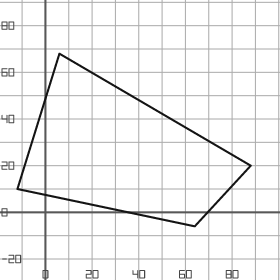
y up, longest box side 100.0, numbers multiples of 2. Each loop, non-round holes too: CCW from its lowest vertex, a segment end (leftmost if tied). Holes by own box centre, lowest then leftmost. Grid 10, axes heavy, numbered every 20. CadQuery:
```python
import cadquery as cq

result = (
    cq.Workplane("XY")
    .moveTo(64.0, -6.0)
    .lineTo(88.0, 20.0)
    .lineTo(6.0, 68.0)
    .lineTo(-12.0, 10.0)
    .close()
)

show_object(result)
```